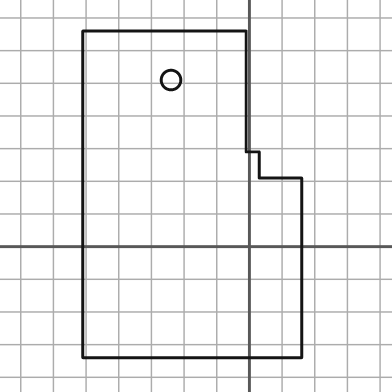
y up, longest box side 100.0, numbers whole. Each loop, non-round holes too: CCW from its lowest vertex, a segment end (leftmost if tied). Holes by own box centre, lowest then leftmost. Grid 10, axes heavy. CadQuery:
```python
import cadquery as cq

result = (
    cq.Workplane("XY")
    .moveTo(-51.0, -34.0)
    .lineTo(16.0, -34.0)
    .lineTo(16.0, 21.0)
    .lineTo(3.0, 21.0)
    .lineTo(3.0, 29.0)
    .lineTo(-1.0, 29.0)
    .lineTo(-1.0, 66.0)
    .lineTo(-51.0, 66.0)
    .close()
    .moveTo(-24.0, 51.0)
    .circle(3.0)
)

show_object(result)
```